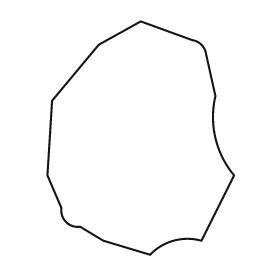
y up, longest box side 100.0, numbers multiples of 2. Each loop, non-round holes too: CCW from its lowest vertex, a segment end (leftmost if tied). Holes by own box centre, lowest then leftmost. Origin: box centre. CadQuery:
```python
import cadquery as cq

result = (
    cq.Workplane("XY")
    .moveTo(4.0, -50.0)
    .threePointArc((14.0, -44.0), (26.0, -44.0))
    .lineTo(40.0, -16.0)
    .threePointArc((32.0, 0.0), (32.0, 18.0))
    .lineTo(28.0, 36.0)
    .threePointArc((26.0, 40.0), (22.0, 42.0))
    .lineTo(0.0, 50.0)
    .lineTo(-18.0, 40.0)
    .lineTo(-38.0, 16.0)
    .lineTo(-40.0, -16.0)
    .lineTo(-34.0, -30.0)
    .threePointArc((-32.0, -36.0), (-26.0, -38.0))
    .lineTo(-16.0, -44.0)
    .close()
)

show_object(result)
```